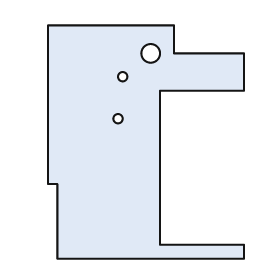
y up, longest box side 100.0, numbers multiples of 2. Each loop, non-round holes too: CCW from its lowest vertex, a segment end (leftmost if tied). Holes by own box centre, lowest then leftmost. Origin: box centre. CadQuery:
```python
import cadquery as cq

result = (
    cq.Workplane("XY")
    .moveTo(-38.0, -50.0)
    .lineTo(42.0, -50.0)
    .lineTo(42.0, -44.0)
    .lineTo(6.0, -44.0)
    .lineTo(6.0, 22.0)
    .lineTo(42.0, 22.0)
    .lineTo(42.0, 38.0)
    .lineTo(12.0, 38.0)
    .lineTo(12.0, 50.0)
    .lineTo(-42.0, 50.0)
    .lineTo(-42.0, -18.0)
    .lineTo(-38.0, -18.0)
    .close()
    .moveTo(-12.0, 10.0)
    .circle(2.0)
    .moveTo(-10.0, 28.0)
    .circle(2.0)
    .moveTo(2.0, 38.0)
    .circle(4.0)
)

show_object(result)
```